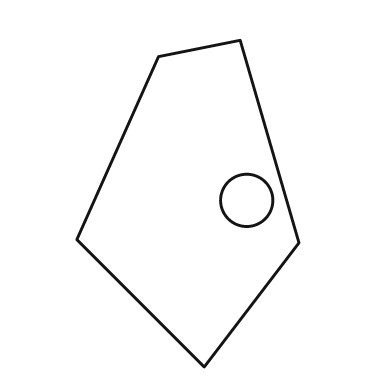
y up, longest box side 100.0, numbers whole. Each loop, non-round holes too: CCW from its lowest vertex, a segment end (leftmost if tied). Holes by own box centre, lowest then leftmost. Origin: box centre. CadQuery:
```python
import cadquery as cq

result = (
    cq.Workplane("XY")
    .moveTo(5.0, -50.0)
    .lineTo(34.0, -12.0)
    .lineTo(16.0, 50.0)
    .lineTo(-9.0, 45.0)
    .lineTo(-34.0, -11.0)
    .close()
    .moveTo(18.0, 1.0)
    .circle(8.0)
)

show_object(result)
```